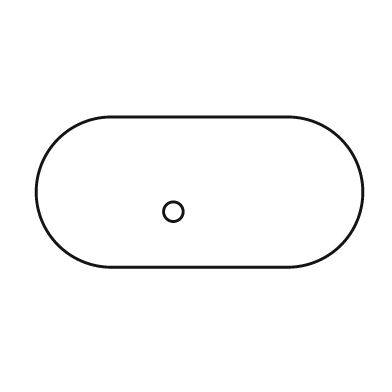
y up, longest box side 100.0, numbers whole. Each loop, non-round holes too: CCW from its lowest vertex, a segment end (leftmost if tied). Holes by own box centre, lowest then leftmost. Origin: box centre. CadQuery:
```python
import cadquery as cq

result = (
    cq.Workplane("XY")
    .moveTo(-27.0, -23.0)
    .lineTo(27.0, -23.0)
    .threePointArc((50.0, 0.0), (27.0, 23.0))
    .lineTo(-27.0, 23.0)
    .threePointArc((-50.0, 0.0), (-27.0, -23.0))
    .close()
    .moveTo(-8.0, -6.0)
    .circle(3.0)
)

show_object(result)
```